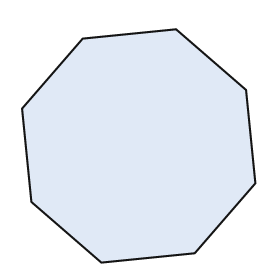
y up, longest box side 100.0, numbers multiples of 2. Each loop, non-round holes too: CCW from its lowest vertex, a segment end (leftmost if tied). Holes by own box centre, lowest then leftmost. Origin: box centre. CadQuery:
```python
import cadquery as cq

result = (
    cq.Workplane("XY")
    .moveTo(-16.0, -50.0)
    .lineTo(24.0, -46.0)
    .lineTo(50.0, -16.0)
    .lineTo(46.0, 24.0)
    .lineTo(16.0, 50.0)
    .lineTo(-24.0, 46.0)
    .lineTo(-50.0, 16.0)
    .lineTo(-46.0, -24.0)
    .close()
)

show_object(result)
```